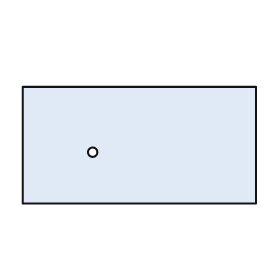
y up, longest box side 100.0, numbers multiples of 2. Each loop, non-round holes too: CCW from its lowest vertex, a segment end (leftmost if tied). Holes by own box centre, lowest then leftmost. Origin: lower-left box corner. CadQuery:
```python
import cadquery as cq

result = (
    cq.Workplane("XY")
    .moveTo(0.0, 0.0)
    .lineTo(100.0, 0.0)
    .lineTo(100.0, 50.0)
    .lineTo(0.0, 50.0)
    .close()
    .moveTo(30.0, 22.0)
    .circle(2.0)
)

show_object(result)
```